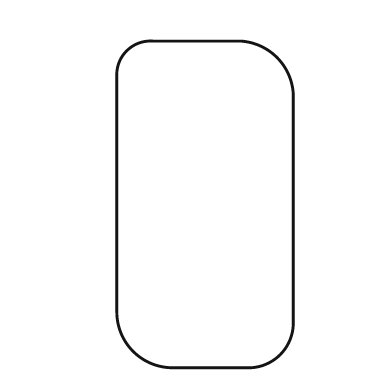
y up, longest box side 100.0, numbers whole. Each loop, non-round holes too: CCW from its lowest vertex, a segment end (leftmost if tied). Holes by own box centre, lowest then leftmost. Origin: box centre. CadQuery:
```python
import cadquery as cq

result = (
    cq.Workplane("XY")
    .moveTo(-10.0, -50.0)
    .lineTo(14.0, -50.0)
    .threePointArc((23.0, -46.0), (27.0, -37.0))
    .lineTo(27.0, 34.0)
    .threePointArc((22.0, 45.0), (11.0, 50.0))
    .lineTo(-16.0, 50.0)
    .threePointArc((-24.0, 47.0), (-27.0, 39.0))
    .lineTo(-27.0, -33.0)
    .threePointArc((-22.0, -45.0), (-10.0, -50.0))
    .close()
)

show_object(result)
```